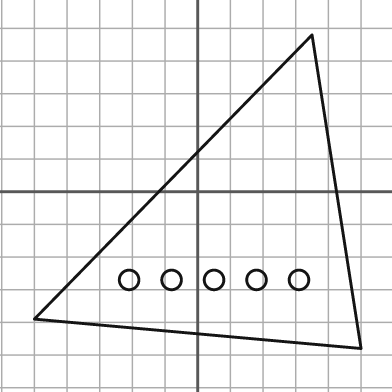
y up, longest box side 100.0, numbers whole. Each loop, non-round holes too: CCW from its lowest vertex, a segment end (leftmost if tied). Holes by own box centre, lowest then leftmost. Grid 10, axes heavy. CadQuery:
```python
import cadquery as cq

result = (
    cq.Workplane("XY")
    .moveTo(50.0, -48.0)
    .lineTo(35.0, 48.0)
    .lineTo(-50.0, -39.0)
    .close()
    .moveTo(-21.0, -27.0)
    .circle(3.0)
    .moveTo(-8.0, -27.0)
    .circle(3.0)
    .moveTo(5.0, -27.0)
    .circle(3.0)
    .moveTo(18.0, -27.0)
    .circle(3.0)
    .moveTo(31.0, -27.0)
    .circle(3.0)
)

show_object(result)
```